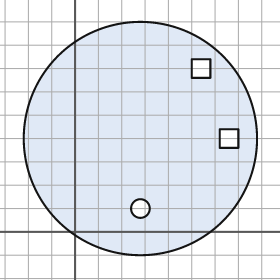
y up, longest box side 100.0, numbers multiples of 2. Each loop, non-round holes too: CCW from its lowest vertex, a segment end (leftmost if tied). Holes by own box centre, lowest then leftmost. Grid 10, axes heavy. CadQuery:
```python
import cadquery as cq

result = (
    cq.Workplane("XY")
    .moveTo(28.0, 40.0)
    .circle(50.0)
    .moveTo(28.0, 10.0)
    .circle(4.0)
    .moveTo(62.0, 36.0)
    .lineTo(70.0, 36.0)
    .lineTo(70.0, 44.0)
    .lineTo(62.0, 44.0)
    .close()
    .moveTo(50.0, 66.0)
    .lineTo(58.0, 66.0)
    .lineTo(58.0, 74.0)
    .lineTo(50.0, 74.0)
    .close()
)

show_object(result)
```